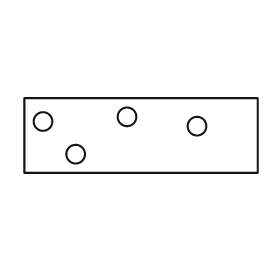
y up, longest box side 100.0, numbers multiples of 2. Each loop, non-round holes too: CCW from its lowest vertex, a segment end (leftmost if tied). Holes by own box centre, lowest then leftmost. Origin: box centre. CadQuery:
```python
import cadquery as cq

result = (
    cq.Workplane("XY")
    .moveTo(-50.0, -16.0)
    .lineTo(50.0, -16.0)
    .lineTo(50.0, 16.0)
    .lineTo(-50.0, 16.0)
    .close()
    .moveTo(-28.0, -8.0)
    .circle(4.0)
    .moveTo(24.0, 4.0)
    .circle(4.0)
    .moveTo(-42.0, 6.0)
    .circle(4.0)
    .moveTo(-6.0, 8.0)
    .circle(4.0)
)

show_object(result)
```